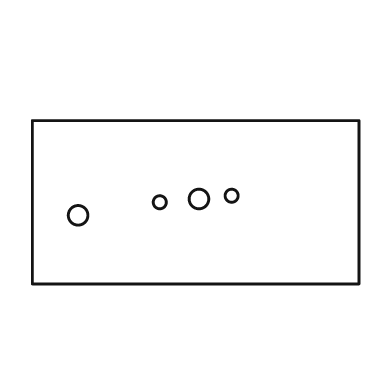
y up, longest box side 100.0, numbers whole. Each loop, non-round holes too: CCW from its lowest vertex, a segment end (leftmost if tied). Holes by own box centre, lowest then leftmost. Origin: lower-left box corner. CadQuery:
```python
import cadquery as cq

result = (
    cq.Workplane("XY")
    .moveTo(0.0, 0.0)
    .lineTo(100.0, 0.0)
    .lineTo(100.0, 50.0)
    .lineTo(0.0, 50.0)
    .close()
    .moveTo(14.0, 21.0)
    .circle(3.0)
    .moveTo(39.0, 25.0)
    .circle(2.0)
    .moveTo(51.0, 26.0)
    .circle(3.0)
    .moveTo(61.0, 27.0)
    .circle(2.0)
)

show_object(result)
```